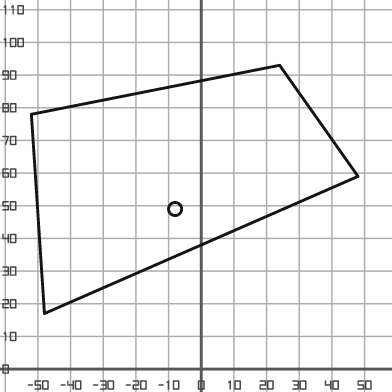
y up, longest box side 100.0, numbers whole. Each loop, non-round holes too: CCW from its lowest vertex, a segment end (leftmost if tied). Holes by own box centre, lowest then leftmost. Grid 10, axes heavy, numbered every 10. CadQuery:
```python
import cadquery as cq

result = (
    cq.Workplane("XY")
    .moveTo(-48.0, 17.0)
    .lineTo(48.0, 59.0)
    .lineTo(24.0, 93.0)
    .lineTo(-52.0, 78.0)
    .close()
    .moveTo(-8.0, 49.0)
    .circle(2.0)
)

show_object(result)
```